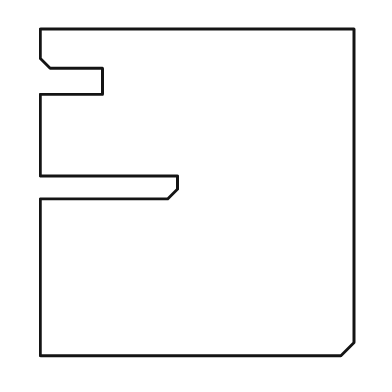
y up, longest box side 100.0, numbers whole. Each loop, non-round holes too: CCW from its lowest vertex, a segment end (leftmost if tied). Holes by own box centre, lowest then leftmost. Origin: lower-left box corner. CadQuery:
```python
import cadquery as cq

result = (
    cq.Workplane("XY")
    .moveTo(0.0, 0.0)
    .lineTo(92.0, 0.0)
    .lineTo(96.0, 4.0)
    .lineTo(96.0, 100.0)
    .lineTo(0.0, 100.0)
    .lineTo(0.0, 91.0)
    .lineTo(3.0, 88.0)
    .lineTo(19.0, 88.0)
    .lineTo(19.0, 80.0)
    .lineTo(0.0, 80.0)
    .lineTo(0.0, 55.0)
    .lineTo(42.0, 55.0)
    .lineTo(42.0, 51.0)
    .lineTo(39.0, 48.0)
    .lineTo(0.0, 48.0)
    .close()
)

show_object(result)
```